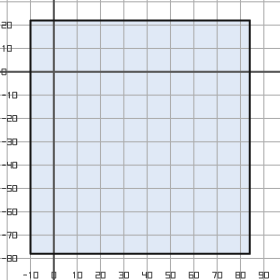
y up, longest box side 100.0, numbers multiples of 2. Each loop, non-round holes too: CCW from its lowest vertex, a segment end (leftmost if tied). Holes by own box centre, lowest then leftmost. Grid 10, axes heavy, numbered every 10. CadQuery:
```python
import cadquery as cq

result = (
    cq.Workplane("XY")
    .moveTo(-10.0, -78.0)
    .lineTo(84.0, -78.0)
    .lineTo(84.0, 22.0)
    .lineTo(-10.0, 22.0)
    .close()
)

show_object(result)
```